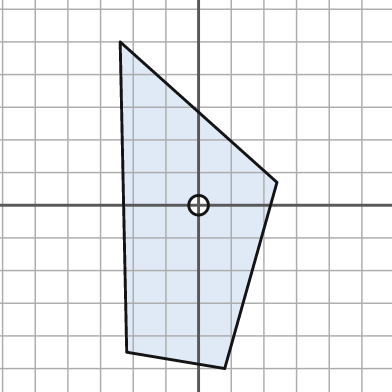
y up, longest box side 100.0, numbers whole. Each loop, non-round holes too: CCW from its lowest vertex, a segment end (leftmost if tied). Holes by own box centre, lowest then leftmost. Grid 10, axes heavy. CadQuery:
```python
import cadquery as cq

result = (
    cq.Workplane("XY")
    .moveTo(8.0, -50.0)
    .lineTo(24.0, 7.0)
    .lineTo(-24.0, 50.0)
    .lineTo(-22.0, -45.0)
    .close()
    .moveTo(0.0, 0.0)
    .circle(3.0)
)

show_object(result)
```